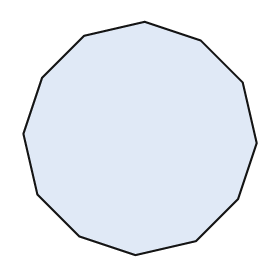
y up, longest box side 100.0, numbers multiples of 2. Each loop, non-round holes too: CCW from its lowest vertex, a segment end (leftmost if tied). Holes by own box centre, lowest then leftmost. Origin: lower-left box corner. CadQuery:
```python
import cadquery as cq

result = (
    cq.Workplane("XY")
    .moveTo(48.0, 0.0)
    .lineTo(74.0, 6.0)
    .lineTo(92.0, 24.0)
    .lineTo(100.0, 48.0)
    .lineTo(94.0, 74.0)
    .lineTo(76.0, 92.0)
    .lineTo(52.0, 100.0)
    .lineTo(26.0, 94.0)
    .lineTo(8.0, 76.0)
    .lineTo(0.0, 52.0)
    .lineTo(6.0, 26.0)
    .lineTo(24.0, 8.0)
    .close()
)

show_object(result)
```